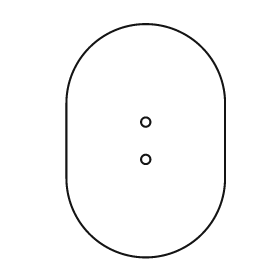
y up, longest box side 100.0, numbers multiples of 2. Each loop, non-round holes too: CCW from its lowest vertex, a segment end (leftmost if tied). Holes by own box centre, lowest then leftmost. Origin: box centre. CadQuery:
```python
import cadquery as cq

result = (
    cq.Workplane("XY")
    .moveTo(-34.0, -16.0)
    .threePointArc((0.0, -50.0), (34.0, -16.0))
    .lineTo(34.0, 16.0)
    .threePointArc((0.0, 50.0), (-34.0, 16.0))
    .close()
    .moveTo(0.0, -8.0)
    .circle(2.0)
    .moveTo(0.0, 8.0)
    .circle(2.0)
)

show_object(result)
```